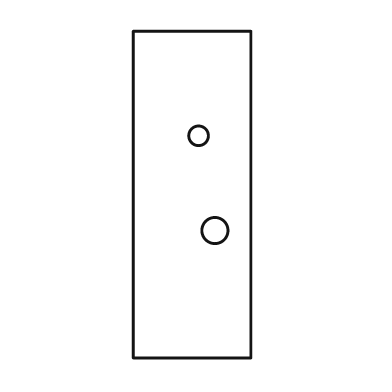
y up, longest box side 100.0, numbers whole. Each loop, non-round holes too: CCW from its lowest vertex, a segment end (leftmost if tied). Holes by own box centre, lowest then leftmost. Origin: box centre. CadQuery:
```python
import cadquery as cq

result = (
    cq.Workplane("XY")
    .moveTo(-18.0, -50.0)
    .lineTo(18.0, -50.0)
    .lineTo(18.0, 50.0)
    .lineTo(-18.0, 50.0)
    .close()
    .moveTo(7.0, -11.0)
    .circle(4.0)
    .moveTo(2.0, 18.0)
    .circle(3.0)
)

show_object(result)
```